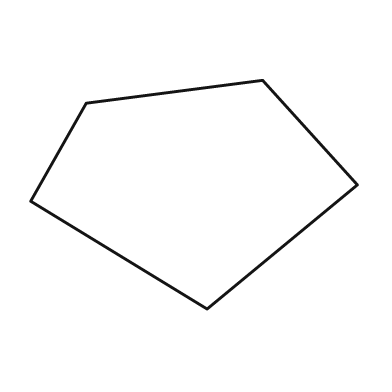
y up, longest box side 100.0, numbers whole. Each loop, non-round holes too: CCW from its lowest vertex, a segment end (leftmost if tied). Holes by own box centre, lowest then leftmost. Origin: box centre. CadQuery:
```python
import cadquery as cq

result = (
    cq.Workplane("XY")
    .moveTo(4.0, -35.0)
    .lineTo(50.0, 3.0)
    .lineTo(21.0, 35.0)
    .lineTo(-33.0, 28.0)
    .lineTo(-50.0, -2.0)
    .close()
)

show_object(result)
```